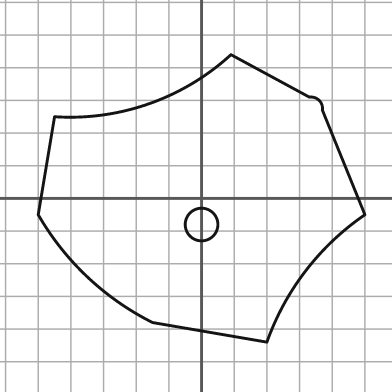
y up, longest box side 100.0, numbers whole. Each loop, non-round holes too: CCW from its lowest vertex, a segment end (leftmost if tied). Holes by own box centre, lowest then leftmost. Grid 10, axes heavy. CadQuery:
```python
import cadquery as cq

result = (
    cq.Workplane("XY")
    .moveTo(20.0, -44.0)
    .threePointArc((32.0, -22.0), (50.0, -5.0))
    .lineTo(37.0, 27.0)
    .threePointArc((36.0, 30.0), (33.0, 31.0))
    .lineTo(9.0, 44.0)
    .threePointArc((-16.0, 29.0), (-45.0, 25.0))
    .lineTo(-50.0, -5.0)
    .threePointArc((-35.0, -24.0), (-15.0, -38.0))
    .close()
    .moveTo(0.0, -8.0)
    .circle(5.0)
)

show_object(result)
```